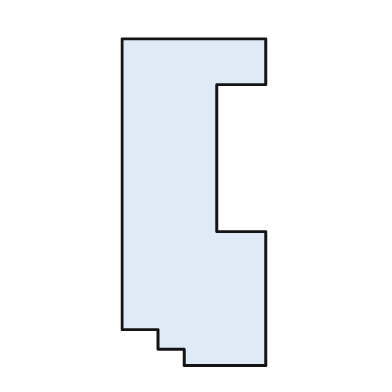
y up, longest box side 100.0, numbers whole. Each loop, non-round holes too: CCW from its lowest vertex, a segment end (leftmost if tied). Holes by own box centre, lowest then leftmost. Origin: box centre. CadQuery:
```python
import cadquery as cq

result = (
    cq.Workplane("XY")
    .moveTo(-3.0, -50.0)
    .lineTo(22.0, -50.0)
    .lineTo(22.0, -9.0)
    .lineTo(7.0, -9.0)
    .lineTo(7.0, 36.0)
    .lineTo(22.0, 36.0)
    .lineTo(22.0, 50.0)
    .lineTo(-22.0, 50.0)
    .lineTo(-22.0, -39.0)
    .lineTo(-11.0, -39.0)
    .lineTo(-11.0, -45.0)
    .lineTo(-3.0, -45.0)
    .close()
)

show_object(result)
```